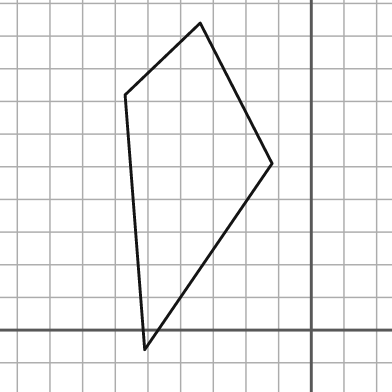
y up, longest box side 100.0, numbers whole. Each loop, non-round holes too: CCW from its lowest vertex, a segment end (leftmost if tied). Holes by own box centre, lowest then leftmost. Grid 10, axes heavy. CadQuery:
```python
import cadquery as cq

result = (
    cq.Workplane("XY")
    .moveTo(-51.0, -6.0)
    .lineTo(-12.0, 51.0)
    .lineTo(-34.0, 94.0)
    .lineTo(-57.0, 72.0)
    .close()
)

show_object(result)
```